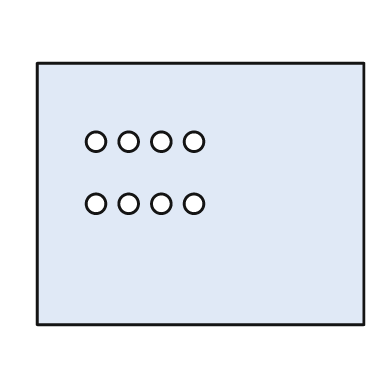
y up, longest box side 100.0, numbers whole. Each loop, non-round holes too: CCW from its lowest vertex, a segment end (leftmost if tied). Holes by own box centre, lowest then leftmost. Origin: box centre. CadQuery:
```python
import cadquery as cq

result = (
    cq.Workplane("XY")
    .moveTo(-50.0, -40.0)
    .lineTo(50.0, -40.0)
    .lineTo(50.0, 40.0)
    .lineTo(-50.0, 40.0)
    .close()
    .moveTo(-32.0, -3.0)
    .circle(3.0)
    .moveTo(-22.0, -3.0)
    .circle(3.0)
    .moveTo(-12.0, -3.0)
    .circle(3.0)
    .moveTo(-2.0, -3.0)
    .circle(3.0)
    .moveTo(-32.0, 16.0)
    .circle(3.0)
    .moveTo(-22.0, 16.0)
    .circle(3.0)
    .moveTo(-12.0, 16.0)
    .circle(3.0)
    .moveTo(-2.0, 16.0)
    .circle(3.0)
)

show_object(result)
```